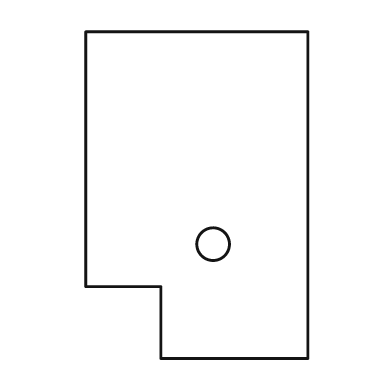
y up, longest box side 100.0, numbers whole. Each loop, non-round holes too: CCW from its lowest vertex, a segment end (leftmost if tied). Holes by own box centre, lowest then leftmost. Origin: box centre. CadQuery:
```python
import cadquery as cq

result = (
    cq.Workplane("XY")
    .moveTo(-11.0, -50.0)
    .lineTo(34.0, -50.0)
    .lineTo(34.0, 50.0)
    .lineTo(-34.0, 50.0)
    .lineTo(-34.0, -28.0)
    .lineTo(-11.0, -28.0)
    .close()
    .moveTo(5.0, -15.0)
    .circle(5.0)
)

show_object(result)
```